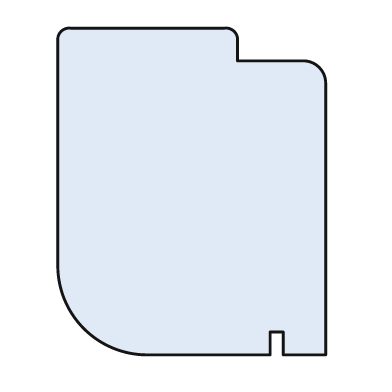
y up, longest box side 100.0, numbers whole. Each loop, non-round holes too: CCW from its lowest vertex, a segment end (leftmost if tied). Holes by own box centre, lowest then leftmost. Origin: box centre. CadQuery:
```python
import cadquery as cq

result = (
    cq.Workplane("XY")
    .moveTo(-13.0, -50.0)
    .lineTo(24.0, -50.0)
    .lineTo(24.0, -43.0)
    .lineTo(28.0, -43.0)
    .lineTo(28.0, -50.0)
    .lineTo(41.0, -50.0)
    .lineTo(41.0, 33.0)
    .threePointArc((39.0, 38.0), (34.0, 40.0))
    .lineTo(14.0, 40.0)
    .lineTo(14.0, 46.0)
    .threePointArc((13.0, 49.0), (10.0, 50.0))
    .lineTo(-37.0, 50.0)
    .threePointArc((-40.0, 49.0), (-41.0, 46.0))
    .lineTo(-41.0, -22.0)
    .threePointArc((-33.0, -42.0), (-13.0, -50.0))
    .close()
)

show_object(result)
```